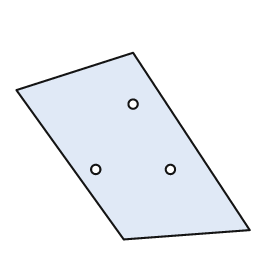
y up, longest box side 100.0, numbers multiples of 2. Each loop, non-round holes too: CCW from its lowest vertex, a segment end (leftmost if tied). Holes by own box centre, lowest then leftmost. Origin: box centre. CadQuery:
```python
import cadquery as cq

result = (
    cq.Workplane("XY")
    .moveTo(-4.0, -40.0)
    .lineTo(50.0, -36.0)
    .lineTo(0.0, 40.0)
    .lineTo(-50.0, 24.0)
    .close()
    .moveTo(-16.0, -10.0)
    .circle(2.0)
    .moveTo(16.0, -10.0)
    .circle(2.0)
    .moveTo(0.0, 18.0)
    .circle(2.0)
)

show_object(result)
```